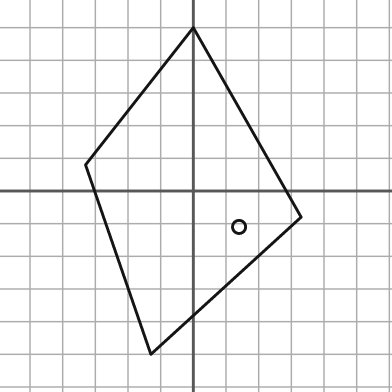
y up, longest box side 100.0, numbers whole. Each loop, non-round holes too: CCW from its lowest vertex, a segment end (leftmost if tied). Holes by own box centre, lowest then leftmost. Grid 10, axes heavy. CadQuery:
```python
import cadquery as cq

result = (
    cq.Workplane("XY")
    .moveTo(-13.0, -50.0)
    .lineTo(33.0, -8.0)
    .lineTo(0.0, 50.0)
    .lineTo(-33.0, 8.0)
    .close()
    .moveTo(14.0, -11.0)
    .circle(2.0)
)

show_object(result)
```